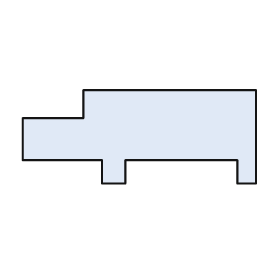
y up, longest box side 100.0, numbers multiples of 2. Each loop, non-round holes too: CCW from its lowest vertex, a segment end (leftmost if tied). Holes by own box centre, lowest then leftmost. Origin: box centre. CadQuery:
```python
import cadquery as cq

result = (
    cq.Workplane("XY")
    .moveTo(-16.0, -20.0)
    .lineTo(-6.0, -20.0)
    .lineTo(-6.0, -10.0)
    .lineTo(42.0, -10.0)
    .lineTo(42.0, -20.0)
    .lineTo(50.0, -20.0)
    .lineTo(50.0, 20.0)
    .lineTo(-24.0, 20.0)
    .lineTo(-24.0, 8.0)
    .lineTo(-50.0, 8.0)
    .lineTo(-50.0, -10.0)
    .lineTo(-16.0, -10.0)
    .close()
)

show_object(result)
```